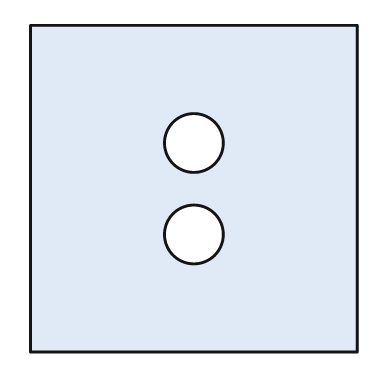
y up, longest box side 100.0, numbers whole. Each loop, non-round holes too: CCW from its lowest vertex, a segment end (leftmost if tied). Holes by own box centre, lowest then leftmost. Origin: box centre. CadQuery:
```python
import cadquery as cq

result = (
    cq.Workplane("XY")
    .moveTo(-50.0, -50.0)
    .lineTo(50.0, -50.0)
    .lineTo(50.0, 50.0)
    .lineTo(-50.0, 50.0)
    .close()
    .moveTo(0.0, -14.0)
    .circle(9.0)
    .moveTo(0.0, 14.0)
    .circle(9.0)
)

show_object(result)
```